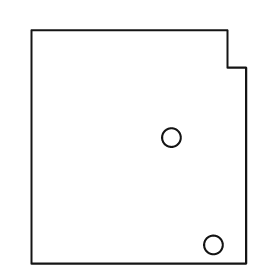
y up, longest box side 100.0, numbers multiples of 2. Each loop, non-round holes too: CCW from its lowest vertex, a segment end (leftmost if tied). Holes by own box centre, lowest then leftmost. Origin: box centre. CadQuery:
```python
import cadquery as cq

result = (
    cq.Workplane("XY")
    .moveTo(-46.0, -50.0)
    .lineTo(46.0, -50.0)
    .lineTo(46.0, 34.0)
    .lineTo(38.0, 34.0)
    .lineTo(38.0, 50.0)
    .lineTo(-46.0, 50.0)
    .close()
    .moveTo(32.0, -42.0)
    .circle(4.0)
    .moveTo(14.0, 4.0)
    .circle(4.0)
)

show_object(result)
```